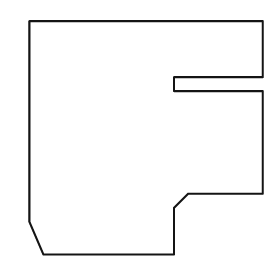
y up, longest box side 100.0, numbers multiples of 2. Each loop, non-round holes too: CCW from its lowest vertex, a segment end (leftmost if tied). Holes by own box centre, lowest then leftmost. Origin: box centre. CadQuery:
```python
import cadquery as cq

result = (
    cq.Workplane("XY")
    .moveTo(-44.0, -50.0)
    .lineTo(12.0, -50.0)
    .lineTo(12.0, -30.0)
    .lineTo(18.0, -24.0)
    .lineTo(50.0, -24.0)
    .lineTo(50.0, 20.0)
    .lineTo(12.0, 20.0)
    .lineTo(12.0, 26.0)
    .lineTo(50.0, 26.0)
    .lineTo(50.0, 50.0)
    .lineTo(-50.0, 50.0)
    .lineTo(-50.0, -36.0)
    .close()
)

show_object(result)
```